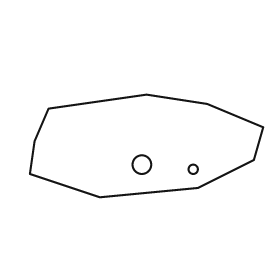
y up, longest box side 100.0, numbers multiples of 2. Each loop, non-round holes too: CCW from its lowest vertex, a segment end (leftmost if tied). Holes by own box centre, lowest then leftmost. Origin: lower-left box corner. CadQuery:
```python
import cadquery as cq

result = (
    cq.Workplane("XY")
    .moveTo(30.0, 0.0)
    .lineTo(72.0, 4.0)
    .lineTo(96.0, 16.0)
    .lineTo(100.0, 30.0)
    .lineTo(76.0, 40.0)
    .lineTo(50.0, 44.0)
    .lineTo(8.0, 38.0)
    .lineTo(2.0, 24.0)
    .lineTo(0.0, 10.0)
    .close()
    .moveTo(70.0, 12.0)
    .circle(2.0)
    .moveTo(48.0, 14.0)
    .circle(4.0)
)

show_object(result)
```